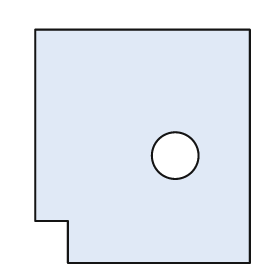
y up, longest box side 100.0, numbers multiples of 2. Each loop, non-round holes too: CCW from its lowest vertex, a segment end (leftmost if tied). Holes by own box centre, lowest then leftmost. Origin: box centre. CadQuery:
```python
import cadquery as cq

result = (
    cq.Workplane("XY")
    .moveTo(-32.0, -50.0)
    .lineTo(46.0, -50.0)
    .lineTo(46.0, 50.0)
    .lineTo(-46.0, 50.0)
    .lineTo(-46.0, -32.0)
    .lineTo(-32.0, -32.0)
    .close()
    .moveTo(14.0, -4.0)
    .circle(10.0)
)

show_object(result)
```